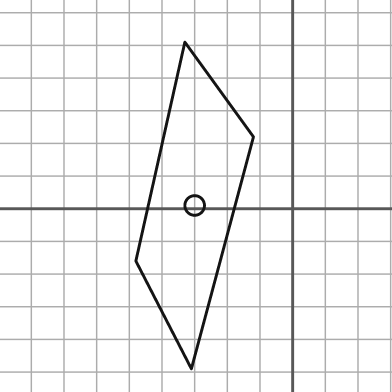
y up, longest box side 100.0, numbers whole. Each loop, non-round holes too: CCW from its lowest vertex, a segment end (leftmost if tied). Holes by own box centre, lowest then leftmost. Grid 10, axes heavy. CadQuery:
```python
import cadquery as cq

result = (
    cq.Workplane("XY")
    .moveTo(-31.0, -49.0)
    .lineTo(-12.0, 22.0)
    .lineTo(-33.0, 51.0)
    .lineTo(-48.0, -16.0)
    .close()
    .moveTo(-30.0, 1.0)
    .circle(3.0)
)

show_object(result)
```